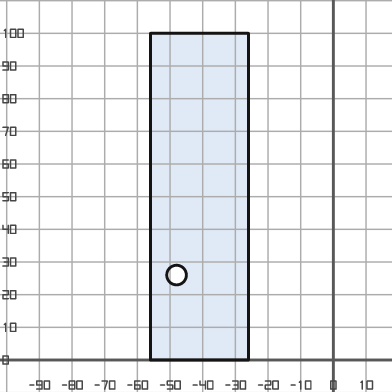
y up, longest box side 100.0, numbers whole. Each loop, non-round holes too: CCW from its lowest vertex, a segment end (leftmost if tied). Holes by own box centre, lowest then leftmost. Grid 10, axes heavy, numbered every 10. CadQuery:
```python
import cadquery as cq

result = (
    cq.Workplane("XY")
    .moveTo(-56.0, 0.0)
    .lineTo(-26.0, 0.0)
    .lineTo(-26.0, 100.0)
    .lineTo(-56.0, 100.0)
    .close()
    .moveTo(-48.0, 26.0)
    .circle(3.0)
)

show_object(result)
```